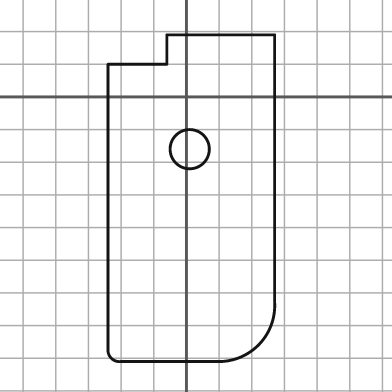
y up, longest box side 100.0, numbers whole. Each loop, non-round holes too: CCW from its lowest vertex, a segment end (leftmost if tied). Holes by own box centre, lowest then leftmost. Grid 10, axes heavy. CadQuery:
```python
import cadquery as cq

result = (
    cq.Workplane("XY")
    .moveTo(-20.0, -81.0)
    .lineTo(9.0, -81.0)
    .threePointArc((22.0, -76.0), (27.0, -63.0))
    .lineTo(27.0, 19.0)
    .lineTo(-6.0, 19.0)
    .lineTo(-6.0, 10.0)
    .lineTo(-24.0, 10.0)
    .lineTo(-24.0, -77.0)
    .threePointArc((-23.0, -80.0), (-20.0, -81.0))
    .close()
    .moveTo(1.0, -16.0)
    .circle(6.0)
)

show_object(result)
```